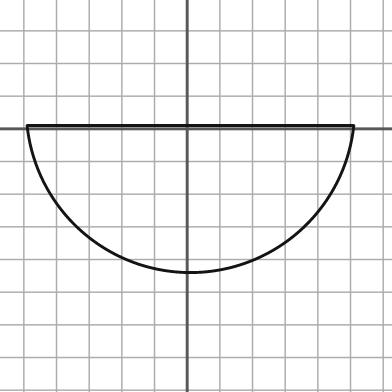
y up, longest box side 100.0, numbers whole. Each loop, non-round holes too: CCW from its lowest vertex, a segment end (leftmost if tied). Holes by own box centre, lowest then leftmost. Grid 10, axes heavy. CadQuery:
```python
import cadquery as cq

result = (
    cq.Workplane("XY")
    .moveTo(-49.0, 1.0)
    .threePointArc((1.0, -44.0), (51.0, 1.0))
    .close()
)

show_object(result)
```